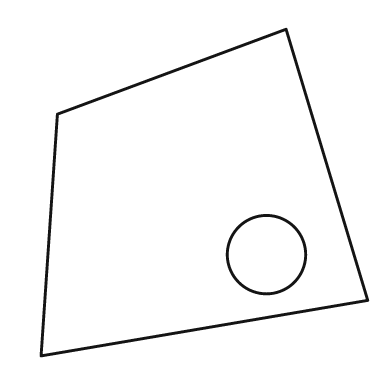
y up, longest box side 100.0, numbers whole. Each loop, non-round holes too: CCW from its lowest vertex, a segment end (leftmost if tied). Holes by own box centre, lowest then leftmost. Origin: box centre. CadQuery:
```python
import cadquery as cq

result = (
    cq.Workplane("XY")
    .moveTo(-50.0, -50.0)
    .lineTo(50.0, -33.0)
    .lineTo(25.0, 50.0)
    .lineTo(-45.0, 24.0)
    .close()
    .moveTo(19.0, -19.0)
    .circle(12.0)
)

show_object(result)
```